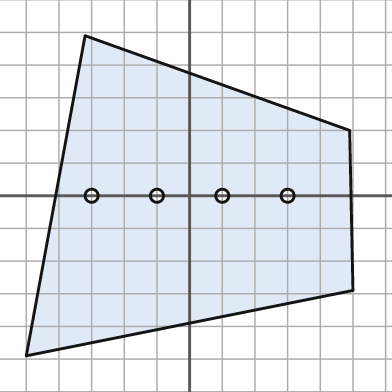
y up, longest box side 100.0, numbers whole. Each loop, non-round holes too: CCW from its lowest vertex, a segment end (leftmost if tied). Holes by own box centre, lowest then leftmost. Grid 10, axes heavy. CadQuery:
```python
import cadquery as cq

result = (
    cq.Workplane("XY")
    .moveTo(-50.0, -49.0)
    .lineTo(50.0, -29.0)
    .lineTo(49.0, 20.0)
    .lineTo(-32.0, 49.0)
    .close()
    .moveTo(-30.0, 0.0)
    .circle(2.0)
    .moveTo(-10.0, 0.0)
    .circle(2.0)
    .moveTo(10.0, 0.0)
    .circle(2.0)
    .moveTo(30.0, 0.0)
    .circle(2.0)
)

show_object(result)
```